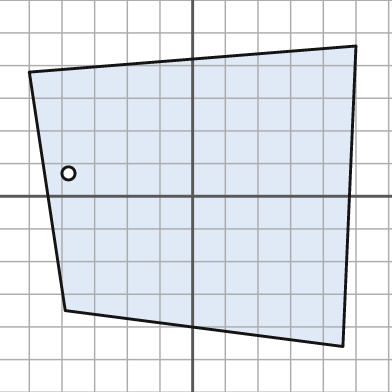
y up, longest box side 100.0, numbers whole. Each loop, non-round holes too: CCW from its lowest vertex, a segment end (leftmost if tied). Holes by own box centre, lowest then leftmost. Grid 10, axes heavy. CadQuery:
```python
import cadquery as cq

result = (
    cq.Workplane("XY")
    .moveTo(46.0, -46.0)
    .lineTo(50.0, 46.0)
    .lineTo(-50.0, 38.0)
    .lineTo(-39.0, -35.0)
    .close()
    .moveTo(-38.0, 7.0)
    .circle(2.0)
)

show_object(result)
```